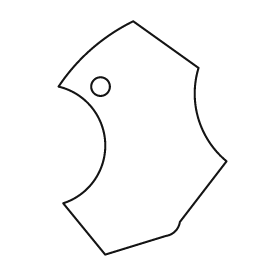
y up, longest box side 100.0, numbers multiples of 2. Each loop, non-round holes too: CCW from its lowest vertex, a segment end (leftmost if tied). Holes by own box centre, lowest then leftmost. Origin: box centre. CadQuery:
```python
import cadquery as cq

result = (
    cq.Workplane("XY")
    .moveTo(-16.0, -50.0)
    .lineTo(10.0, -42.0)
    .threePointArc((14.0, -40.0), (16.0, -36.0))
    .lineTo(36.0, -10.0)
    .threePointArc((24.0, 8.0), (24.0, 30.0))
    .lineTo(-4.0, 50.0)
    .threePointArc((-22.0, 38.0), (-36.0, 22.0))
    .threePointArc((-16.0, -2.0), (-34.0, -28.0))
    .close()
    .moveTo(-18.0, 22.0)
    .circle(4.0)
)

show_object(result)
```